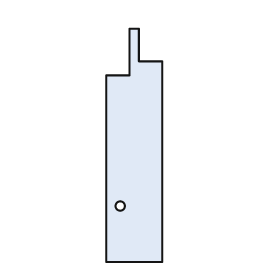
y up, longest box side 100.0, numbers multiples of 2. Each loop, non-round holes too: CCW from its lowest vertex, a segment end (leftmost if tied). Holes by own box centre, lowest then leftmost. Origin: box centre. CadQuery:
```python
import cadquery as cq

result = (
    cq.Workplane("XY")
    .moveTo(-12.0, -50.0)
    .lineTo(12.0, -50.0)
    .lineTo(12.0, 36.0)
    .lineTo(2.0, 36.0)
    .lineTo(2.0, 50.0)
    .lineTo(-2.0, 50.0)
    .lineTo(-2.0, 30.0)
    .lineTo(-12.0, 30.0)
    .close()
    .moveTo(-6.0, -26.0)
    .circle(2.0)
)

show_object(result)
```